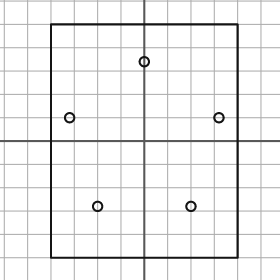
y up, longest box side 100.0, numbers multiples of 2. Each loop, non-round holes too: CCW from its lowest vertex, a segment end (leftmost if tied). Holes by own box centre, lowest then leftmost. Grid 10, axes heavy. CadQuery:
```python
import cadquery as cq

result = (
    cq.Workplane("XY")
    .moveTo(-40.0, -50.0)
    .lineTo(40.0, -50.0)
    .lineTo(40.0, 50.0)
    .lineTo(-40.0, 50.0)
    .close()
    .moveTo(-20.0, -28.0)
    .circle(2.0)
    .moveTo(20.0, -28.0)
    .circle(2.0)
    .moveTo(-32.0, 10.0)
    .circle(2.0)
    .moveTo(32.0, 10.0)
    .circle(2.0)
    .moveTo(0.0, 34.0)
    .circle(2.0)
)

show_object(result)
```